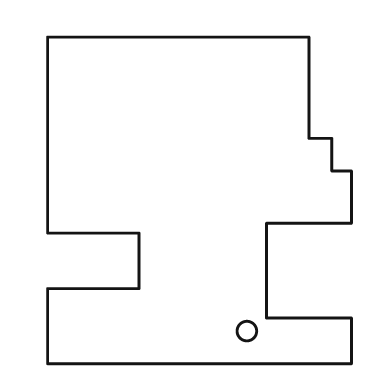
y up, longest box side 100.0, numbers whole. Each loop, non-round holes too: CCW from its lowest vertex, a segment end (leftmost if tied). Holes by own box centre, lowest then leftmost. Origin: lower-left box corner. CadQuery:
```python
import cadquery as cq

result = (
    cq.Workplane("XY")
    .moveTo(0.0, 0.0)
    .lineTo(93.0, 0.0)
    .lineTo(93.0, 14.0)
    .lineTo(67.0, 14.0)
    .lineTo(67.0, 43.0)
    .lineTo(93.0, 43.0)
    .lineTo(93.0, 59.0)
    .lineTo(87.0, 59.0)
    .lineTo(87.0, 69.0)
    .lineTo(80.0, 69.0)
    .lineTo(80.0, 100.0)
    .lineTo(0.0, 100.0)
    .lineTo(0.0, 40.0)
    .lineTo(28.0, 40.0)
    .lineTo(28.0, 23.0)
    .lineTo(0.0, 23.0)
    .close()
    .moveTo(61.0, 10.0)
    .circle(3.0)
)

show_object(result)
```